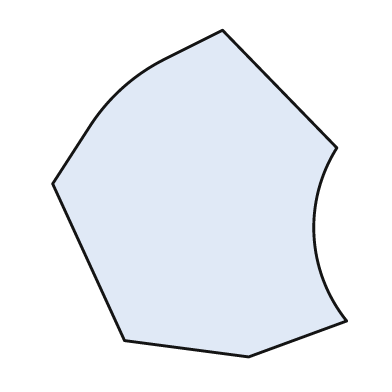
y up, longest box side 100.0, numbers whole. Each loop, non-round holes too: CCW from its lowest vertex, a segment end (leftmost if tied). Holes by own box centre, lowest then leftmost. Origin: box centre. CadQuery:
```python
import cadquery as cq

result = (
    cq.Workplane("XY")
    .moveTo(15.0, -50.0)
    .lineTo(45.0, -39.0)
    .threePointArc((35.0, -13.0), (42.0, 14.0))
    .lineTo(7.0, 50.0)
    .lineTo(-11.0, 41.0)
    .threePointArc((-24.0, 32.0), (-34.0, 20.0))
    .lineTo(-45.0, 3.0)
    .lineTo(-23.0, -45.0)
    .close()
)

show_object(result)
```